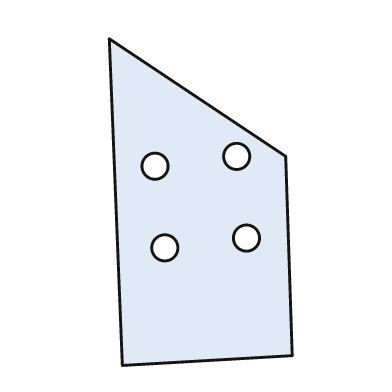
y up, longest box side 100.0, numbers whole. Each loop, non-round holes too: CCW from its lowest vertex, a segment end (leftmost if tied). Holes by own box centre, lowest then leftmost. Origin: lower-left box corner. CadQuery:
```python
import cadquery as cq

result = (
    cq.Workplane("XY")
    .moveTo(4.0, 0.0)
    .lineTo(56.0, 3.0)
    .lineTo(54.0, 64.0)
    .lineTo(0.0, 100.0)
    .close()
    .moveTo(17.0, 36.0)
    .circle(4.0)
    .moveTo(42.0, 39.0)
    .circle(4.0)
    .moveTo(14.0, 61.0)
    .circle(4.0)
    .moveTo(39.0, 64.0)
    .circle(4.0)
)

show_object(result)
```